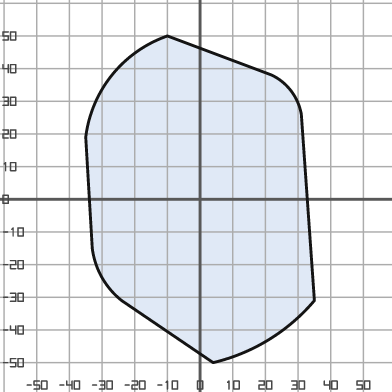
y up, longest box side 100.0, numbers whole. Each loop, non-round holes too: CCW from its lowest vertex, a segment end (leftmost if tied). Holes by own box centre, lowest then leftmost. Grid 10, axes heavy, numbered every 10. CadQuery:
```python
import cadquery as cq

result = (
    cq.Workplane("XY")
    .moveTo(4.0, -50.0)
    .threePointArc((21.0, -43.0), (35.0, -31.0))
    .lineTo(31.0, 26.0)
    .threePointArc((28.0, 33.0), (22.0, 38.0))
    .lineTo(-10.0, 50.0)
    .threePointArc((-27.0, 38.0), (-35.0, 19.0))
    .lineTo(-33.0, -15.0)
    .threePointArc((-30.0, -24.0), (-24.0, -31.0))
    .close()
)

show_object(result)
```